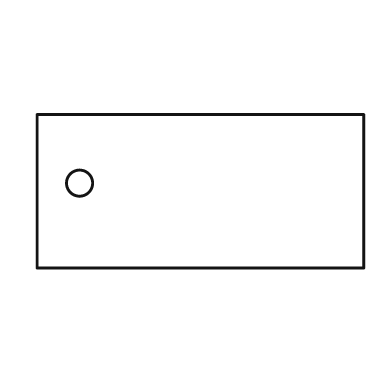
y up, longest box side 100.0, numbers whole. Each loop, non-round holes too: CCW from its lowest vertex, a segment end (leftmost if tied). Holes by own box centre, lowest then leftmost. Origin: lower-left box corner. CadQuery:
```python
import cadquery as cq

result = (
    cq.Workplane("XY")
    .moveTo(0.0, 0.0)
    .lineTo(100.0, 0.0)
    .lineTo(100.0, 47.0)
    .lineTo(0.0, 47.0)
    .close()
    .moveTo(13.0, 26.0)
    .circle(4.0)
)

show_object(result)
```